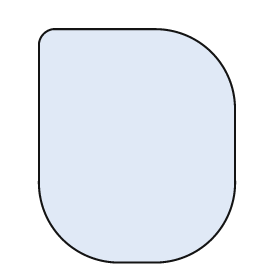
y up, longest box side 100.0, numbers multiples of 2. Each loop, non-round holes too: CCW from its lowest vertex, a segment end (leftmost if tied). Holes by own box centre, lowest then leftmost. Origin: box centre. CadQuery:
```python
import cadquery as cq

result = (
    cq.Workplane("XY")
    .moveTo(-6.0, -50.0)
    .lineTo(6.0, -50.0)
    .threePointArc((32.0, -40.0), (42.0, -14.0))
    .lineTo(42.0, 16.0)
    .threePointArc((32.0, 40.0), (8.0, 50.0))
    .lineTo(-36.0, 50.0)
    .threePointArc((-40.0, 48.0), (-42.0, 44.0))
    .lineTo(-42.0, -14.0)
    .threePointArc((-32.0, -40.0), (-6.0, -50.0))
    .close()
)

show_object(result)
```